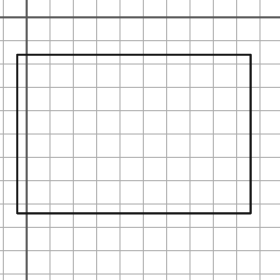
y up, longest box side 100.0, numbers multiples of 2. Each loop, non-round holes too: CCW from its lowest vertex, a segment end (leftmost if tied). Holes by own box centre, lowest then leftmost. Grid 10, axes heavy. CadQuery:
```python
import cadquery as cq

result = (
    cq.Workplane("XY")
    .moveTo(-4.0, -84.0)
    .lineTo(96.0, -84.0)
    .lineTo(96.0, -16.0)
    .lineTo(-4.0, -16.0)
    .close()
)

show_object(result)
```